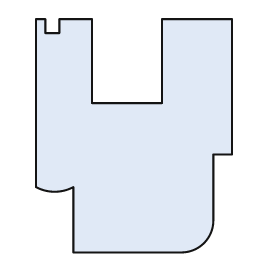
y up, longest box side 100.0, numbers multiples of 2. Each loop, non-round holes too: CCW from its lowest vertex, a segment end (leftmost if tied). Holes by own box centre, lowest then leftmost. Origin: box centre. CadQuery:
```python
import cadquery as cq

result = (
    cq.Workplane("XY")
    .moveTo(-26.0, -50.0)
    .lineTo(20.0, -50.0)
    .threePointArc((30.0, -46.0), (34.0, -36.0))
    .lineTo(34.0, -8.0)
    .lineTo(42.0, -8.0)
    .lineTo(42.0, 50.0)
    .lineTo(12.0, 50.0)
    .lineTo(12.0, 14.0)
    .lineTo(-18.0, 14.0)
    .lineTo(-18.0, 50.0)
    .lineTo(-32.0, 50.0)
    .lineTo(-32.0, 44.0)
    .lineTo(-38.0, 44.0)
    .lineTo(-38.0, 50.0)
    .lineTo(-42.0, 50.0)
    .lineTo(-42.0, -22.0)
    .threePointArc((-34.0, -24.0), (-26.0, -22.0))
    .close()
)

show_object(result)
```